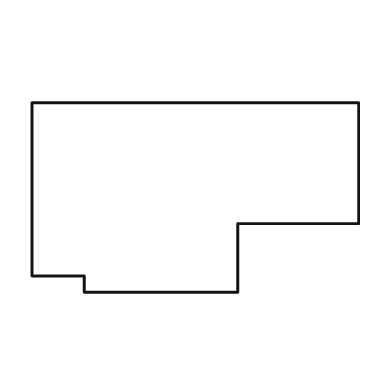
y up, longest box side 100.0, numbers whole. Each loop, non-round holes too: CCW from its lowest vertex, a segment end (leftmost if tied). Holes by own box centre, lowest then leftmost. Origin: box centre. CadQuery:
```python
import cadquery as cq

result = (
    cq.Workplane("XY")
    .moveTo(-34.0, -29.0)
    .lineTo(13.0, -29.0)
    .lineTo(13.0, -8.0)
    .lineTo(50.0, -8.0)
    .lineTo(50.0, 29.0)
    .lineTo(-50.0, 29.0)
    .lineTo(-50.0, -24.0)
    .lineTo(-34.0, -24.0)
    .close()
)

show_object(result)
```